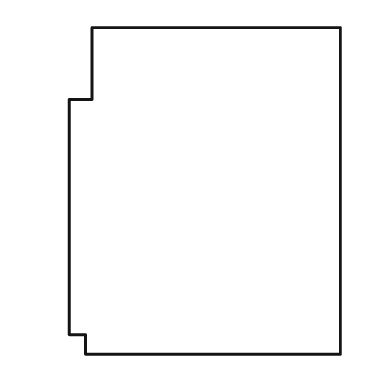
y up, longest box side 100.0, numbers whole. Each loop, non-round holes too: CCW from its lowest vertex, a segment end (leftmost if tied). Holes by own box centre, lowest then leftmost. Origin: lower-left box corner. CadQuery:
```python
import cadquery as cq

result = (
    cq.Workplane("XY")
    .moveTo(5.0, 0.0)
    .lineTo(83.0, 0.0)
    .lineTo(83.0, 100.0)
    .lineTo(7.0, 100.0)
    .lineTo(7.0, 78.0)
    .lineTo(0.0, 78.0)
    .lineTo(0.0, 6.0)
    .lineTo(5.0, 6.0)
    .close()
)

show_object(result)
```